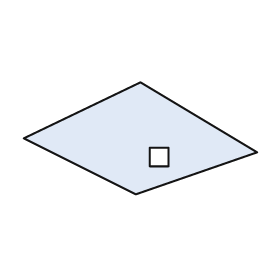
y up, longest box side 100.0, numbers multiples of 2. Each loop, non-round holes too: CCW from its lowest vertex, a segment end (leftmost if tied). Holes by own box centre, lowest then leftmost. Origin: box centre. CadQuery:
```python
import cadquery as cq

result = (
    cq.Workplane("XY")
    .moveTo(-2.0, -24.0)
    .lineTo(50.0, -6.0)
    .lineTo(0.0, 24.0)
    .lineTo(-50.0, 0.0)
    .close()
    .moveTo(4.0, -12.0)
    .lineTo(12.0, -12.0)
    .lineTo(12.0, -4.0)
    .lineTo(4.0, -4.0)
    .close()
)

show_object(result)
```